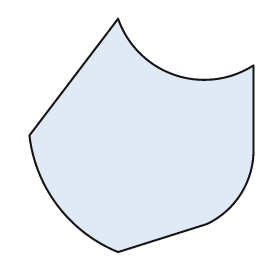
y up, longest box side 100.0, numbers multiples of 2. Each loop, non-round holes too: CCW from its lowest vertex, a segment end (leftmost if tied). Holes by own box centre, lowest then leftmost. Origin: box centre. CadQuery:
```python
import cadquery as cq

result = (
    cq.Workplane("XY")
    .moveTo(-10.0, -50.0)
    .lineTo(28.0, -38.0)
    .threePointArc((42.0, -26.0), (48.0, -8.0))
    .lineTo(48.0, 30.0)
    .threePointArc((14.0, 26.0), (-10.0, 50.0))
    .lineTo(-48.0, 0.0)
    .threePointArc((-36.0, -30.0), (-10.0, -50.0))
    .close()
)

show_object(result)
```